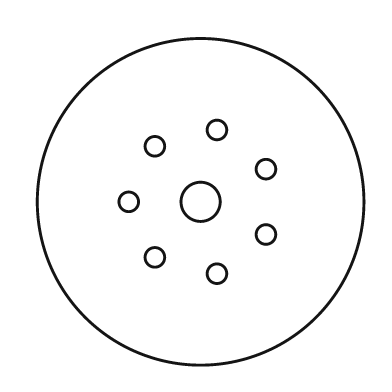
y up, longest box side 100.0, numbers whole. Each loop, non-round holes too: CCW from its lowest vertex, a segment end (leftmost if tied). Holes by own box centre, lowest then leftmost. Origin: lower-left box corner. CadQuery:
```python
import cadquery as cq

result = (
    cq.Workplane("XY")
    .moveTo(50.0, 50.0)
    .circle(50.0)
    .moveTo(55.0, 28.0)
    .circle(3.0)
    .moveTo(36.0, 33.0)
    .circle(3.0)
    .moveTo(70.0, 40.0)
    .circle(3.0)
    .moveTo(28.0, 50.0)
    .circle(3.0)
    .moveTo(50.0, 50.0)
    .circle(6.0)
    .moveTo(70.0, 60.0)
    .circle(3.0)
    .moveTo(36.0, 67.0)
    .circle(3.0)
    .moveTo(55.0, 72.0)
    .circle(3.0)
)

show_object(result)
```